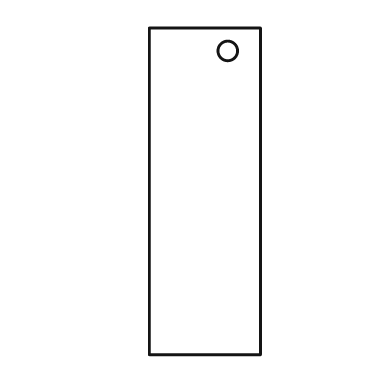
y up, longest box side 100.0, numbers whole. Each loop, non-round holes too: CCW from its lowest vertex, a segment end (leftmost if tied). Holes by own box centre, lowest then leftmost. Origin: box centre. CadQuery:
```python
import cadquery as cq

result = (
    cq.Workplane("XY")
    .moveTo(-17.0, -50.0)
    .lineTo(17.0, -50.0)
    .lineTo(17.0, 50.0)
    .lineTo(-17.0, 50.0)
    .close()
    .moveTo(7.0, 43.0)
    .circle(3.0)
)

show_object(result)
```